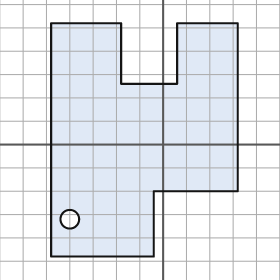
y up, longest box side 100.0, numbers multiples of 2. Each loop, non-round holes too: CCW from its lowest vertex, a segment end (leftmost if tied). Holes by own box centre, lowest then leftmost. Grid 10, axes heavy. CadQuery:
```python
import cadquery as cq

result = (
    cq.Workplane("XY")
    .moveTo(-48.0, -48.0)
    .lineTo(-4.0, -48.0)
    .lineTo(-4.0, -20.0)
    .lineTo(32.0, -20.0)
    .lineTo(32.0, 52.0)
    .lineTo(6.0, 52.0)
    .lineTo(6.0, 26.0)
    .lineTo(-18.0, 26.0)
    .lineTo(-18.0, 52.0)
    .lineTo(-48.0, 52.0)
    .close()
    .moveTo(-40.0, -32.0)
    .circle(4.0)
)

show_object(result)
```